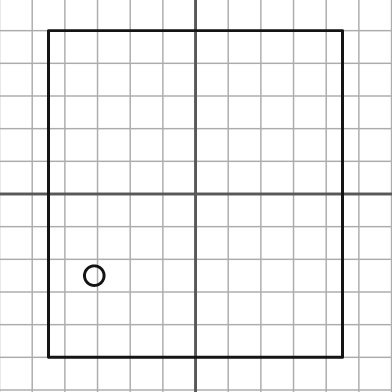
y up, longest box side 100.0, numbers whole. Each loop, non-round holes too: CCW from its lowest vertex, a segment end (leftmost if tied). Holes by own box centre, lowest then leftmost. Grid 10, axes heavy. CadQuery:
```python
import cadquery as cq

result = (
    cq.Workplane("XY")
    .moveTo(-45.0, -50.0)
    .lineTo(45.0, -50.0)
    .lineTo(45.0, 50.0)
    .lineTo(-45.0, 50.0)
    .close()
    .moveTo(-31.0, -25.0)
    .circle(3.0)
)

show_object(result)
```